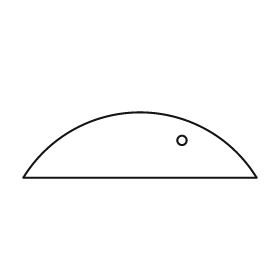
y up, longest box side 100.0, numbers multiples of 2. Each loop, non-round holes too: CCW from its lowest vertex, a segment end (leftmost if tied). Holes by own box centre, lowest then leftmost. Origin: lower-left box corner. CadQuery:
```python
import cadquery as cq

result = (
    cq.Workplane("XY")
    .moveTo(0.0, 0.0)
    .lineTo(100.0, 0.0)
    .threePointArc((50.0, 28.0), (0.0, 0.0))
    .close()
    .moveTo(68.0, 16.0)
    .circle(2.0)
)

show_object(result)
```